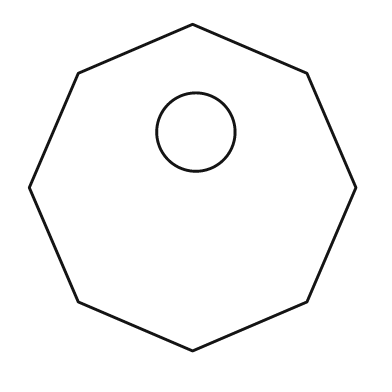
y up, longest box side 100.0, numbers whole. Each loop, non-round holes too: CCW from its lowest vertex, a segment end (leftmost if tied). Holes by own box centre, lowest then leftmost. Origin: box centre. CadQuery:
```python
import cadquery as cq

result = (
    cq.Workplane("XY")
    .moveTo(0.0, -50.0)
    .lineTo(35.0, -35.0)
    .lineTo(50.0, 0.0)
    .lineTo(35.0, 35.0)
    .lineTo(0.0, 50.0)
    .lineTo(-35.0, 35.0)
    .lineTo(-50.0, 0.0)
    .lineTo(-35.0, -35.0)
    .close()
    .moveTo(1.0, 17.0)
    .circle(12.0)
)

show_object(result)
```